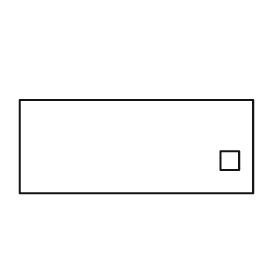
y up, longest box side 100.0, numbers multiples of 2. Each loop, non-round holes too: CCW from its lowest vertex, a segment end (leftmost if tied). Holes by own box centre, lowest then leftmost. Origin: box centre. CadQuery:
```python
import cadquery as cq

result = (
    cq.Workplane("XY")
    .moveTo(-50.0, -20.0)
    .lineTo(50.0, -20.0)
    .lineTo(50.0, 20.0)
    .lineTo(-50.0, 20.0)
    .close()
    .moveTo(36.0, -10.0)
    .lineTo(44.0, -10.0)
    .lineTo(44.0, -2.0)
    .lineTo(36.0, -2.0)
    .close()
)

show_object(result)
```